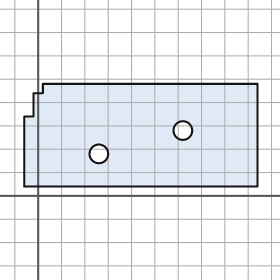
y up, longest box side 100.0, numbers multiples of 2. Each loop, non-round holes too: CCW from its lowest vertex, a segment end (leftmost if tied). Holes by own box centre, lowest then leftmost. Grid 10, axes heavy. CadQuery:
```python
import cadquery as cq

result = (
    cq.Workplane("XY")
    .moveTo(-6.0, 4.0)
    .lineTo(94.0, 4.0)
    .lineTo(94.0, 48.0)
    .lineTo(2.0, 48.0)
    .lineTo(2.0, 44.0)
    .lineTo(-2.0, 44.0)
    .lineTo(-2.0, 34.0)
    .lineTo(-6.0, 34.0)
    .close()
    .moveTo(26.0, 18.0)
    .circle(4.0)
    .moveTo(62.0, 28.0)
    .circle(4.0)
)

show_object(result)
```